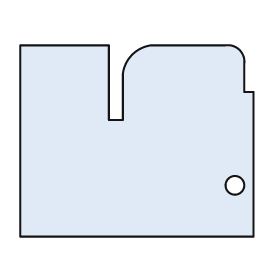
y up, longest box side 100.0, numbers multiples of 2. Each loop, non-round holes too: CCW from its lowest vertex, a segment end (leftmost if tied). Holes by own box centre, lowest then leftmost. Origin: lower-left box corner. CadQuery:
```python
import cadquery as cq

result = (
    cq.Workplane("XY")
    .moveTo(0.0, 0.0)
    .lineTo(100.0, 0.0)
    .lineTo(100.0, 62.0)
    .lineTo(96.0, 62.0)
    .lineTo(96.0, 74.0)
    .threePointArc((94.0, 80.0), (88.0, 82.0))
    .lineTo(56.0, 82.0)
    .threePointArc((48.0, 78.0), (44.0, 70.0))
    .lineTo(44.0, 50.0)
    .lineTo(38.0, 50.0)
    .lineTo(38.0, 82.0)
    .lineTo(0.0, 82.0)
    .close()
    .moveTo(92.0, 22.0)
    .circle(4.0)
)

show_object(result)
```